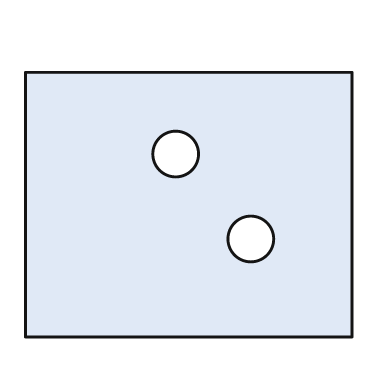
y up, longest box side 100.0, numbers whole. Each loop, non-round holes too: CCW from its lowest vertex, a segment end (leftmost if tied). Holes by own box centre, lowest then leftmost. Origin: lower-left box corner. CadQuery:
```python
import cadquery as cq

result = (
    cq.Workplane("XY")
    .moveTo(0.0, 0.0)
    .lineTo(100.0, 0.0)
    .lineTo(100.0, 81.0)
    .lineTo(0.0, 81.0)
    .close()
    .moveTo(69.0, 30.0)
    .circle(7.0)
    .moveTo(46.0, 56.0)
    .circle(7.0)
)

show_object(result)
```